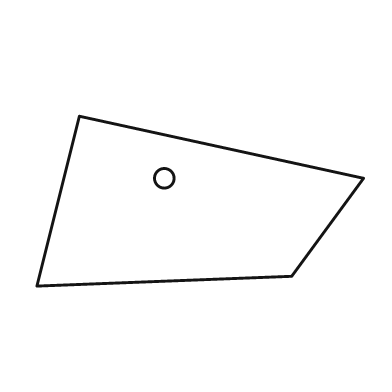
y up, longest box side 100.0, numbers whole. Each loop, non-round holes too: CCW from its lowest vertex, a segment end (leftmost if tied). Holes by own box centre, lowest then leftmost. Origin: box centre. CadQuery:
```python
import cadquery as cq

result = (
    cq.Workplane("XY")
    .moveTo(-50.0, -26.0)
    .lineTo(28.0, -23.0)
    .lineTo(50.0, 7.0)
    .lineTo(-37.0, 26.0)
    .close()
    .moveTo(-11.0, 7.0)
    .circle(3.0)
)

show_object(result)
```